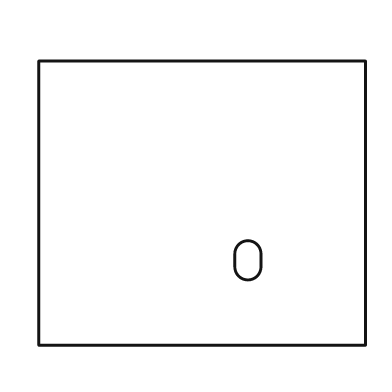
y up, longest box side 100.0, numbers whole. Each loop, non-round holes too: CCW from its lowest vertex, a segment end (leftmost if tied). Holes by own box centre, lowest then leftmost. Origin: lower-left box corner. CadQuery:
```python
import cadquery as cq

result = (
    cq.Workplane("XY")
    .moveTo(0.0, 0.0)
    .lineTo(100.0, 0.0)
    .lineTo(100.0, 87.0)
    .lineTo(0.0, 87.0)
    .close()
    .moveTo(60.0, 24.0)
    .threePointArc((64.0, 20.0), (68.0, 24.0))
    .lineTo(68.0, 28.0)
    .threePointArc((64.0, 32.0), (60.0, 28.0))
    .close()
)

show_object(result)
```